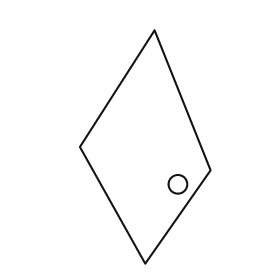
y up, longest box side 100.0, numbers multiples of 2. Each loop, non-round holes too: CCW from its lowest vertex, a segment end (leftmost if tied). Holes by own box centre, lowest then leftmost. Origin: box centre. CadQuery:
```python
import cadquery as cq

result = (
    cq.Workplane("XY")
    .moveTo(0.0, -50.0)
    .lineTo(28.0, -10.0)
    .lineTo(4.0, 50.0)
    .lineTo(-28.0, 0.0)
    .close()
    .moveTo(14.0, -16.0)
    .circle(4.0)
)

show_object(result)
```